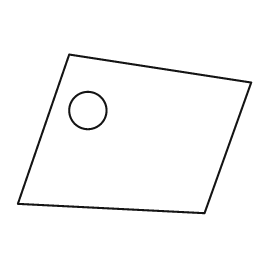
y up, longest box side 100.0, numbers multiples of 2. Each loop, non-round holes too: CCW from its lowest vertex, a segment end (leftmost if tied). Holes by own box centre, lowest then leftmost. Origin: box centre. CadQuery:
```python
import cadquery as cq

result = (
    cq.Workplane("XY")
    .moveTo(30.0, -34.0)
    .lineTo(50.0, 22.0)
    .lineTo(-28.0, 34.0)
    .lineTo(-50.0, -30.0)
    .close()
    .moveTo(-20.0, 10.0)
    .circle(8.0)
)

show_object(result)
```